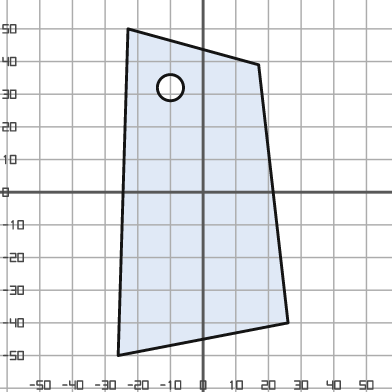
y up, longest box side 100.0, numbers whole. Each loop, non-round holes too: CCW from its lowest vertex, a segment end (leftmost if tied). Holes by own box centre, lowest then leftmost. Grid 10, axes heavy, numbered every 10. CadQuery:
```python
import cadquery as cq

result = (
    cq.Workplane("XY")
    .moveTo(-26.0, -50.0)
    .lineTo(26.0, -40.0)
    .lineTo(17.0, 39.0)
    .lineTo(-23.0, 50.0)
    .close()
    .moveTo(-10.0, 32.0)
    .circle(4.0)
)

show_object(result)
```